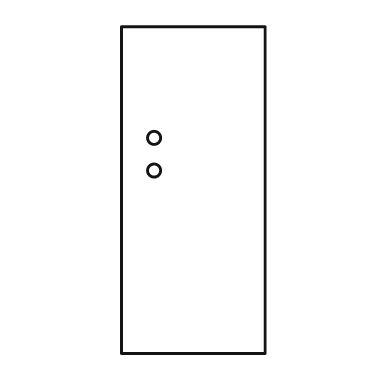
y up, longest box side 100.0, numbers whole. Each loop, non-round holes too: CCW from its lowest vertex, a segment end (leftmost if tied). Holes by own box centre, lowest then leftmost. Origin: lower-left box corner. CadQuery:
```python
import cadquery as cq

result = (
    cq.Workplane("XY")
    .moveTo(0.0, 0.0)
    .lineTo(44.0, 0.0)
    .lineTo(44.0, 100.0)
    .lineTo(0.0, 100.0)
    .close()
    .moveTo(10.0, 56.0)
    .circle(2.0)
    .moveTo(10.0, 66.0)
    .circle(2.0)
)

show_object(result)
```